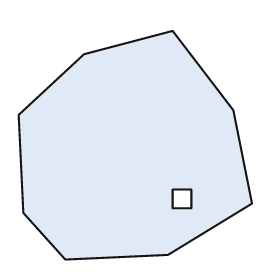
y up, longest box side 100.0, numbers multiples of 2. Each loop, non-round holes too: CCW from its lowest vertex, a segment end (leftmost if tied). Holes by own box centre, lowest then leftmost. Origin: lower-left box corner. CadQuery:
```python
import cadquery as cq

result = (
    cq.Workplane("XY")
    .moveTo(20.0, 0.0)
    .lineTo(64.0, 2.0)
    .lineTo(100.0, 24.0)
    .lineTo(92.0, 64.0)
    .lineTo(66.0, 98.0)
    .lineTo(28.0, 88.0)
    .lineTo(0.0, 62.0)
    .lineTo(2.0, 20.0)
    .close()
    .moveTo(66.0, 22.0)
    .lineTo(74.0, 22.0)
    .lineTo(74.0, 30.0)
    .lineTo(66.0, 30.0)
    .close()
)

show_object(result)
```